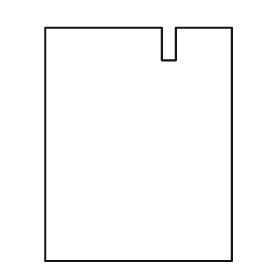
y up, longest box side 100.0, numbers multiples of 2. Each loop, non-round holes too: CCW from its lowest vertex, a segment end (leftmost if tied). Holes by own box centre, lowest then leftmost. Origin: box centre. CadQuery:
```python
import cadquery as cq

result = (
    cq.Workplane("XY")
    .moveTo(-40.0, -50.0)
    .lineTo(40.0, -50.0)
    .lineTo(40.0, 50.0)
    .lineTo(16.0, 50.0)
    .lineTo(16.0, 36.0)
    .lineTo(10.0, 36.0)
    .lineTo(10.0, 50.0)
    .lineTo(-40.0, 50.0)
    .close()
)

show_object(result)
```